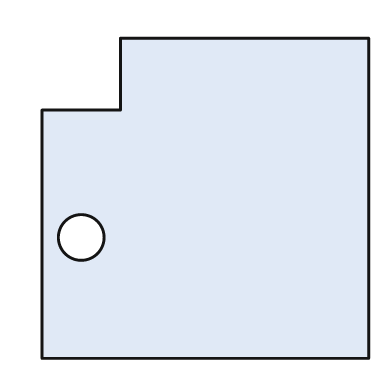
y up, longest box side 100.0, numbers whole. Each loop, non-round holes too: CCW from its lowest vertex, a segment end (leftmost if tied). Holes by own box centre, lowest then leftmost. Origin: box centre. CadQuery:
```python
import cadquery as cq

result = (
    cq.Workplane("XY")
    .moveTo(-50.0, -49.0)
    .lineTo(50.0, -49.0)
    .lineTo(50.0, 49.0)
    .lineTo(-26.0, 49.0)
    .lineTo(-26.0, 27.0)
    .lineTo(-50.0, 27.0)
    .close()
    .moveTo(-38.0, -12.0)
    .circle(7.0)
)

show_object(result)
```